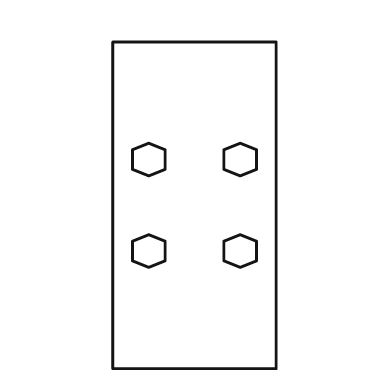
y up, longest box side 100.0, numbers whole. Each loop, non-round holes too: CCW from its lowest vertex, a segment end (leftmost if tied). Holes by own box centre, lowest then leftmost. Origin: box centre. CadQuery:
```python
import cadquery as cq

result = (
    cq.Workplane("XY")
    .moveTo(-25.0, -50.0)
    .lineTo(25.0, -50.0)
    .lineTo(25.0, 50.0)
    .lineTo(-25.0, 50.0)
    .close()
    .moveTo(-14.0, -19.0)
    .lineTo(-9.0, -17.0)
    .lineTo(-9.0, -11.0)
    .lineTo(-14.0, -9.0)
    .lineTo(-19.0, -11.0)
    .lineTo(-19.0, -17.0)
    .close()
    .moveTo(14.0, -19.0)
    .lineTo(19.0, -17.0)
    .lineTo(19.0, -11.0)
    .lineTo(14.0, -9.0)
    .lineTo(9.0, -11.0)
    .lineTo(9.0, -17.0)
    .close()
    .moveTo(-14.0, 9.0)
    .lineTo(-9.0, 11.0)
    .lineTo(-9.0, 17.0)
    .lineTo(-14.0, 19.0)
    .lineTo(-19.0, 17.0)
    .lineTo(-19.0, 11.0)
    .close()
    .moveTo(14.0, 9.0)
    .lineTo(19.0, 11.0)
    .lineTo(19.0, 17.0)
    .lineTo(14.0, 19.0)
    .lineTo(9.0, 17.0)
    .lineTo(9.0, 11.0)
    .close()
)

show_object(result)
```